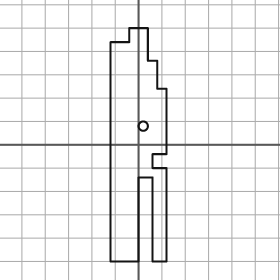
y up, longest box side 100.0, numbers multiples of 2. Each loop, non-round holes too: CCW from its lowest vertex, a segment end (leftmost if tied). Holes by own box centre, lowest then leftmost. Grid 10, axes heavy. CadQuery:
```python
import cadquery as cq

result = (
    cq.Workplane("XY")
    .moveTo(-12.0, -50.0)
    .lineTo(0.0, -50.0)
    .lineTo(0.0, -14.0)
    .lineTo(6.0, -14.0)
    .lineTo(6.0, -50.0)
    .lineTo(12.0, -50.0)
    .lineTo(12.0, -10.0)
    .lineTo(6.0, -10.0)
    .lineTo(6.0, -4.0)
    .lineTo(12.0, -4.0)
    .lineTo(12.0, 24.0)
    .lineTo(8.0, 24.0)
    .lineTo(8.0, 36.0)
    .lineTo(4.0, 36.0)
    .lineTo(4.0, 50.0)
    .lineTo(-4.0, 50.0)
    .lineTo(-4.0, 44.0)
    .lineTo(-12.0, 44.0)
    .close()
    .moveTo(2.0, 8.0)
    .circle(2.0)
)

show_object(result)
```